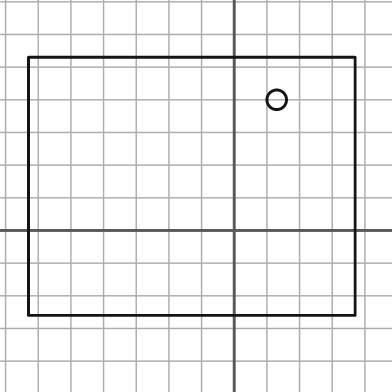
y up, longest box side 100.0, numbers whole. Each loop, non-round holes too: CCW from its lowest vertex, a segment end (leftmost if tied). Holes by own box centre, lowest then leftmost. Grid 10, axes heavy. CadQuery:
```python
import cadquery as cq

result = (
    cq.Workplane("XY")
    .moveTo(-63.0, -26.0)
    .lineTo(37.0, -26.0)
    .lineTo(37.0, 53.0)
    .lineTo(-63.0, 53.0)
    .close()
    .moveTo(13.0, 40.0)
    .circle(3.0)
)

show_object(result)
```